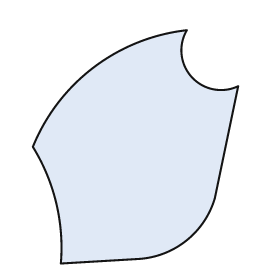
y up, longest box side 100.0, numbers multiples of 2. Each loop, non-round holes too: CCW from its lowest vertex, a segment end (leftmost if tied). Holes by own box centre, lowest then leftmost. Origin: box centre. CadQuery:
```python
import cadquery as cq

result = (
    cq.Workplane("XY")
    .moveTo(-32.0, -50.0)
    .lineTo(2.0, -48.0)
    .threePointArc((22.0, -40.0), (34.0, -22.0))
    .lineTo(44.0, 26.0)
    .threePointArc((24.0, 30.0), (22.0, 50.0))
    .threePointArc((-18.0, 34.0), (-44.0, 0.0))
    .threePointArc((-34.0, -24.0), (-32.0, -50.0))
    .close()
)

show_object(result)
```